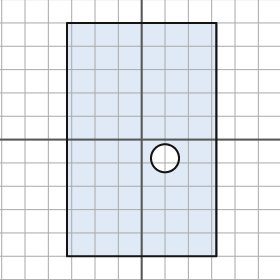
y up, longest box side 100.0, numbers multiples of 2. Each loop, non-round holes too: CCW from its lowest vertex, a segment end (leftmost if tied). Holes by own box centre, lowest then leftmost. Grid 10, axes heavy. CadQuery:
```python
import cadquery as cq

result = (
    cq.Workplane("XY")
    .moveTo(-32.0, -50.0)
    .lineTo(32.0, -50.0)
    .lineTo(32.0, 50.0)
    .lineTo(-32.0, 50.0)
    .close()
    .moveTo(10.0, -8.0)
    .circle(6.0)
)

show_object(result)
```